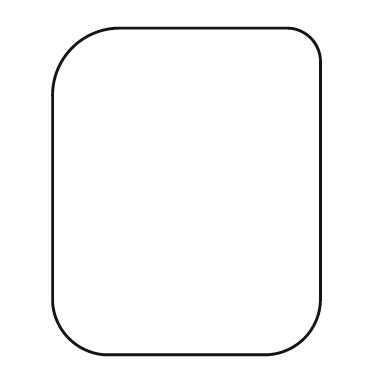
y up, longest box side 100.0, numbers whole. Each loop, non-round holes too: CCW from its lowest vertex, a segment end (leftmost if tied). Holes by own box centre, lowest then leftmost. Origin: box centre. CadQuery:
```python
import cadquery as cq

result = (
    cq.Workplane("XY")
    .moveTo(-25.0, -50.0)
    .lineTo(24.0, -50.0)
    .threePointArc((36.0, -45.0), (41.0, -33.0))
    .lineTo(41.0, 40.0)
    .threePointArc((38.0, 47.0), (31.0, 50.0))
    .lineTo(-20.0, 50.0)
    .threePointArc((-35.0, 44.0), (-41.0, 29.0))
    .lineTo(-41.0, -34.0)
    .threePointArc((-36.0, -45.0), (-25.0, -50.0))
    .close()
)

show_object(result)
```